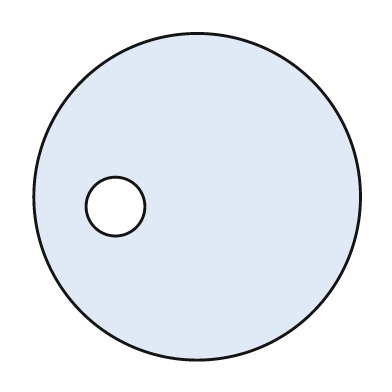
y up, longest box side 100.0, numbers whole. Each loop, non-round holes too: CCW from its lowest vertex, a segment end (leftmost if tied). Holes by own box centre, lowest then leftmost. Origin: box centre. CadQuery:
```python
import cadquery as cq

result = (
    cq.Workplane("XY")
    .moveTo(0.0, 0.0)
    .circle(50.0)
    .moveTo(-25.0, -3.0)
    .circle(9.0)
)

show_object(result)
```